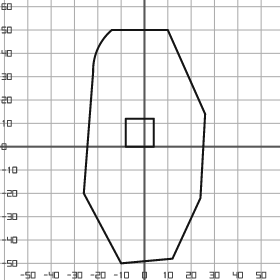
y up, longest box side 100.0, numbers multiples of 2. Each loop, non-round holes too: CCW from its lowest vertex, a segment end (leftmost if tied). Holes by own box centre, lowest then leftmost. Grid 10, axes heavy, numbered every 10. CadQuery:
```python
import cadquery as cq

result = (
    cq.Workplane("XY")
    .moveTo(-10.0, -50.0)
    .lineTo(12.0, -48.0)
    .lineTo(24.0, -22.0)
    .lineTo(26.0, 14.0)
    .lineTo(10.0, 50.0)
    .lineTo(-14.0, 50.0)
    .threePointArc((-20.0, 42.0), (-22.0, 32.0))
    .lineTo(-26.0, -20.0)
    .close()
    .moveTo(-8.0, 0.0)
    .lineTo(4.0, 0.0)
    .lineTo(4.0, 12.0)
    .lineTo(-8.0, 12.0)
    .close()
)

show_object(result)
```